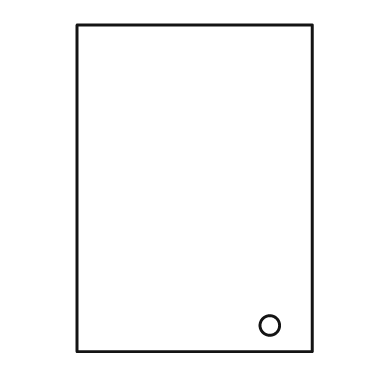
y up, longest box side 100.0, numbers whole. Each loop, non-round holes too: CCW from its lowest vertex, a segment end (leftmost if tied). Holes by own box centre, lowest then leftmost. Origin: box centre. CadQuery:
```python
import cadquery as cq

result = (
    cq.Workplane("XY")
    .moveTo(-36.0, -50.0)
    .lineTo(36.0, -50.0)
    .lineTo(36.0, 50.0)
    .lineTo(-36.0, 50.0)
    .close()
    .moveTo(23.0, -42.0)
    .circle(3.0)
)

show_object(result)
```